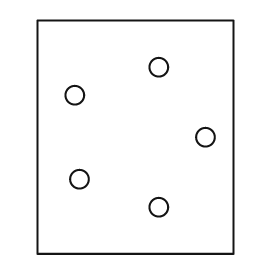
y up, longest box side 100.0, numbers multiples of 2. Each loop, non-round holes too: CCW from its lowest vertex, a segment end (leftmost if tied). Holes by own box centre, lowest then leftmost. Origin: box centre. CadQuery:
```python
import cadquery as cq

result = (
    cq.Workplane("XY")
    .moveTo(-42.0, -50.0)
    .lineTo(42.0, -50.0)
    .lineTo(42.0, 50.0)
    .lineTo(-42.0, 50.0)
    .close()
    .moveTo(10.0, -30.0)
    .circle(4.0)
    .moveTo(-24.0, -18.0)
    .circle(4.0)
    .moveTo(30.0, 0.0)
    .circle(4.0)
    .moveTo(-26.0, 18.0)
    .circle(4.0)
    .moveTo(10.0, 30.0)
    .circle(4.0)
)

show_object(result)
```